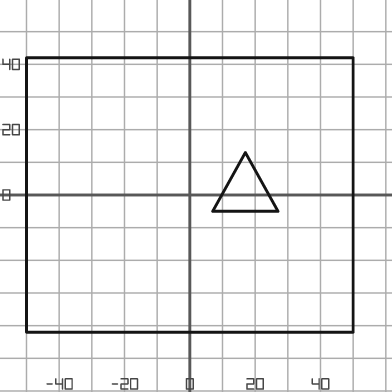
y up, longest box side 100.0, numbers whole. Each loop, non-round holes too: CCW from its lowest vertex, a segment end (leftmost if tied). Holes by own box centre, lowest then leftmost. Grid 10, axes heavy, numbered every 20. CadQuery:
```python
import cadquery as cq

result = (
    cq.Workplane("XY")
    .moveTo(-50.0, -42.0)
    .lineTo(50.0, -42.0)
    .lineTo(50.0, 42.0)
    .lineTo(-50.0, 42.0)
    .close()
    .moveTo(7.0, -5.0)
    .lineTo(27.0, -5.0)
    .lineTo(17.0, 13.0)
    .close()
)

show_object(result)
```